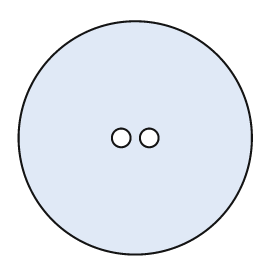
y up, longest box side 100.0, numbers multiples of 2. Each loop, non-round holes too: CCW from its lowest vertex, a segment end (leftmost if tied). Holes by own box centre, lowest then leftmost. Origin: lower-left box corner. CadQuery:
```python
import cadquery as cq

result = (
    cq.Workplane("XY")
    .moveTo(50.0, 50.0)
    .circle(50.0)
    .moveTo(44.0, 50.0)
    .circle(4.0)
    .moveTo(56.0, 50.0)
    .circle(4.0)
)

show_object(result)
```